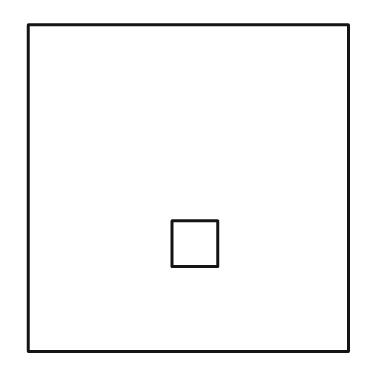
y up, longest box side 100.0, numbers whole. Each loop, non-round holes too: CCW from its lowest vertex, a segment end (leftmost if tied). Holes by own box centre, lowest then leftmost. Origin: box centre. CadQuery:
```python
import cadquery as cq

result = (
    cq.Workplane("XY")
    .moveTo(-49.0, -50.0)
    .lineTo(49.0, -50.0)
    .lineTo(49.0, 50.0)
    .lineTo(-49.0, 50.0)
    .close()
    .moveTo(-5.0, -24.0)
    .lineTo(9.0, -24.0)
    .lineTo(9.0, -10.0)
    .lineTo(-5.0, -10.0)
    .close()
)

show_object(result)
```